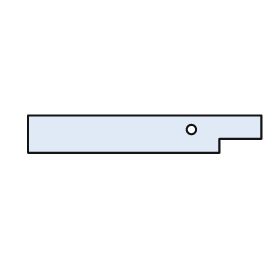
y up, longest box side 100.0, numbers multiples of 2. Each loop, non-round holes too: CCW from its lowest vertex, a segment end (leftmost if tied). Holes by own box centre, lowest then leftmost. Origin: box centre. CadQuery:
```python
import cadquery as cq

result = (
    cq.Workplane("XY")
    .moveTo(-50.0, -8.0)
    .lineTo(32.0, -8.0)
    .lineTo(32.0, -2.0)
    .lineTo(50.0, -2.0)
    .lineTo(50.0, 8.0)
    .lineTo(-50.0, 8.0)
    .close()
    .moveTo(20.0, 2.0)
    .circle(2.0)
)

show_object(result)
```